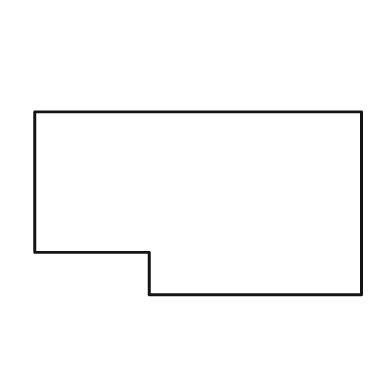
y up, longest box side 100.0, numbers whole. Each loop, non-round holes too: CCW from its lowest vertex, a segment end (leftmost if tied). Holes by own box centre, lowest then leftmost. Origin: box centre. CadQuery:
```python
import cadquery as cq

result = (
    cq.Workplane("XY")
    .moveTo(-15.0, -28.0)
    .lineTo(50.0, -28.0)
    .lineTo(50.0, 28.0)
    .lineTo(-50.0, 28.0)
    .lineTo(-50.0, -15.0)
    .lineTo(-15.0, -15.0)
    .close()
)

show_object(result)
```